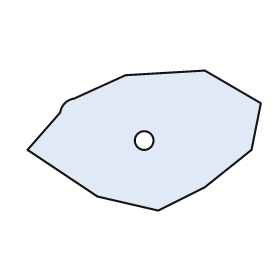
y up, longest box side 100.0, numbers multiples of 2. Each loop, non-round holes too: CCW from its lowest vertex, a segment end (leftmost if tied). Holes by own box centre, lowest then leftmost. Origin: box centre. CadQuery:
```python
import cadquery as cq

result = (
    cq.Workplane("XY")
    .moveTo(6.0, -30.0)
    .lineTo(26.0, -20.0)
    .lineTo(46.0, -4.0)
    .lineTo(50.0, 16.0)
    .lineTo(26.0, 30.0)
    .lineTo(-8.0, 28.0)
    .lineTo(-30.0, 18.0)
    .threePointArc((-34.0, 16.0), (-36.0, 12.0))
    .lineTo(-50.0, -4.0)
    .lineTo(-20.0, -24.0)
    .close()
    .moveTo(0.0, 0.0)
    .circle(4.0)
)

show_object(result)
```